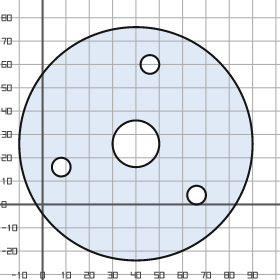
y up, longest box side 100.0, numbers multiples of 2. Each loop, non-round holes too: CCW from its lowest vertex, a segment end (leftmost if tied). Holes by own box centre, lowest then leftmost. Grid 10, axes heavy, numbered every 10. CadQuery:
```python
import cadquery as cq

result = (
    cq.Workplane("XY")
    .moveTo(40.0, 26.0)
    .circle(50.0)
    .moveTo(66.0, 4.0)
    .circle(4.0)
    .moveTo(8.0, 16.0)
    .circle(4.0)
    .moveTo(40.0, 26.0)
    .circle(10.0)
    .moveTo(46.0, 60.0)
    .circle(4.0)
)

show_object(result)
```